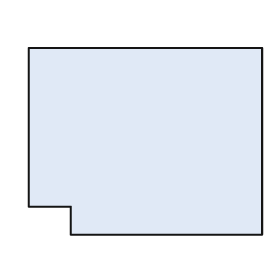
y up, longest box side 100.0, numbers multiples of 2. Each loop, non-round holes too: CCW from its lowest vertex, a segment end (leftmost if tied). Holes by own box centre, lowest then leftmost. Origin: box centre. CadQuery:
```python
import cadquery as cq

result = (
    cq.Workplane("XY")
    .moveTo(-32.0, -40.0)
    .lineTo(50.0, -40.0)
    .lineTo(50.0, 40.0)
    .lineTo(-50.0, 40.0)
    .lineTo(-50.0, -28.0)
    .lineTo(-32.0, -28.0)
    .close()
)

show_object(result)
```